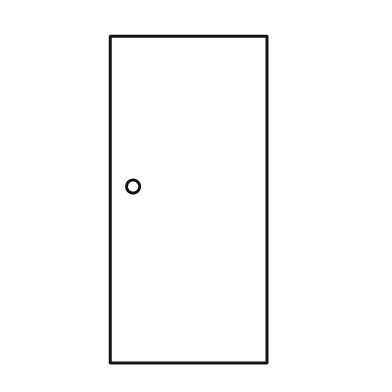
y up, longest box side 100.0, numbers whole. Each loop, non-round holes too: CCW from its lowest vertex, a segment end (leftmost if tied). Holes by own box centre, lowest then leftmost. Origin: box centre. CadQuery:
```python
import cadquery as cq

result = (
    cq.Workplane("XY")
    .moveTo(-24.0, -50.0)
    .lineTo(24.0, -50.0)
    .lineTo(24.0, 50.0)
    .lineTo(-24.0, 50.0)
    .close()
    .moveTo(-17.0, 4.0)
    .circle(2.0)
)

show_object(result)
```